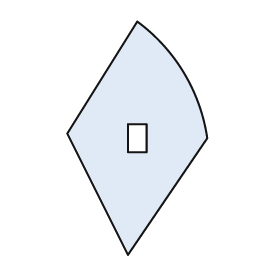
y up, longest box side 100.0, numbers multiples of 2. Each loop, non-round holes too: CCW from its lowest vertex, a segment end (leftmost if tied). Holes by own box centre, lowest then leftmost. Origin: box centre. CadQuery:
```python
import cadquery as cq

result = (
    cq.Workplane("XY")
    .moveTo(-4.0, -50.0)
    .lineTo(30.0, 0.0)
    .threePointArc((20.0, 28.0), (0.0, 50.0))
    .lineTo(-30.0, 2.0)
    .close()
    .moveTo(-4.0, -6.0)
    .lineTo(4.0, -6.0)
    .lineTo(4.0, 6.0)
    .lineTo(-4.0, 6.0)
    .close()
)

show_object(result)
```